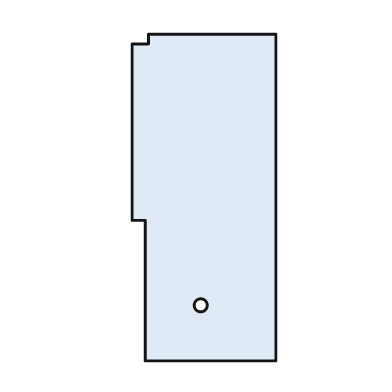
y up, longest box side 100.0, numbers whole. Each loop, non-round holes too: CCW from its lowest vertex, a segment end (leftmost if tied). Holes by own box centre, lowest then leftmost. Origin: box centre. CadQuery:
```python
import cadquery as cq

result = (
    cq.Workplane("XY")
    .moveTo(-18.0, -50.0)
    .lineTo(22.0, -50.0)
    .lineTo(22.0, 50.0)
    .lineTo(-17.0, 50.0)
    .lineTo(-17.0, 47.0)
    .lineTo(-22.0, 47.0)
    .lineTo(-22.0, -7.0)
    .lineTo(-18.0, -7.0)
    .close()
    .moveTo(-1.0, -33.0)
    .circle(2.0)
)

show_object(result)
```